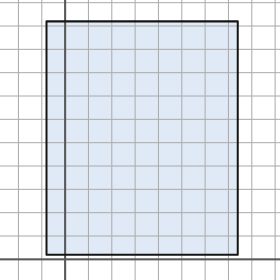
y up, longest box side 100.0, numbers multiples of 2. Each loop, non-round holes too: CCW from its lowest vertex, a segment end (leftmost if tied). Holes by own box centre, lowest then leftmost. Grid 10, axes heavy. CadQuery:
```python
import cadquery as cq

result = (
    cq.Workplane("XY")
    .moveTo(-8.0, 2.0)
    .lineTo(74.0, 2.0)
    .lineTo(74.0, 102.0)
    .lineTo(-8.0, 102.0)
    .close()
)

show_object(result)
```